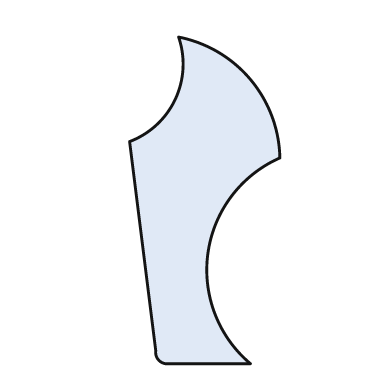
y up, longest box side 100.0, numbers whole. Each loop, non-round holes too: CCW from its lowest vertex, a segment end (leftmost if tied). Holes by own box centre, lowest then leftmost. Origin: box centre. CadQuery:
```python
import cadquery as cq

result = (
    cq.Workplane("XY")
    .moveTo(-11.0, -50.0)
    .lineTo(14.0, -50.0)
    .threePointArc((1.0, -16.0), (23.0, 13.0))
    .threePointArc((14.0, 37.0), (-8.0, 50.0))
    .threePointArc((-9.0, 31.0), (-23.0, 18.0))
    .lineTo(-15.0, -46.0)
    .threePointArc((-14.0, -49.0), (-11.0, -50.0))
    .close()
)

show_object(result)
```